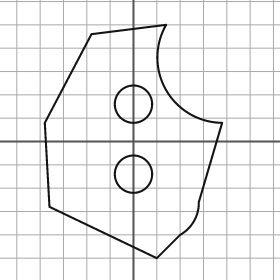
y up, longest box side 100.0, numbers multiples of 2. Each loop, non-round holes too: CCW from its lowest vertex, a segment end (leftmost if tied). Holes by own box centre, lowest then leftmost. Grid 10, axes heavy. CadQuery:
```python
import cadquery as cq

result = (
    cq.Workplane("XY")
    .moveTo(10.0, -50.0)
    .lineTo(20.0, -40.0)
    .threePointArc((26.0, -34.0), (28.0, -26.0))
    .lineTo(38.0, 8.0)
    .threePointArc((14.0, 22.0), (14.0, 50.0))
    .lineTo(-18.0, 46.0)
    .lineTo(-38.0, 8.0)
    .lineTo(-36.0, -28.0)
    .close()
    .moveTo(0.0, -14.0)
    .circle(8.0)
    .moveTo(0.0, 16.0)
    .circle(8.0)
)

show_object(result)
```